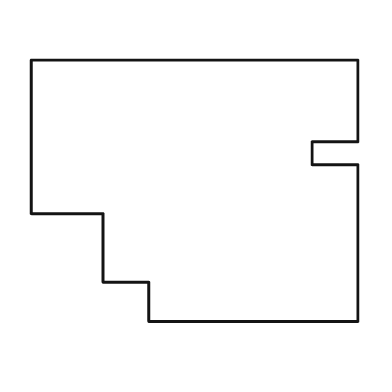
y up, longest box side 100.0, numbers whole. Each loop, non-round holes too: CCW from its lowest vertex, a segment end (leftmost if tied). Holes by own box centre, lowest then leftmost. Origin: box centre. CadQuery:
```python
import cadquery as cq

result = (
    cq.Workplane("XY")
    .moveTo(-14.0, -40.0)
    .lineTo(50.0, -40.0)
    .lineTo(50.0, 8.0)
    .lineTo(36.0, 8.0)
    .lineTo(36.0, 15.0)
    .lineTo(50.0, 15.0)
    .lineTo(50.0, 40.0)
    .lineTo(-50.0, 40.0)
    .lineTo(-50.0, -7.0)
    .lineTo(-28.0, -7.0)
    .lineTo(-28.0, -28.0)
    .lineTo(-14.0, -28.0)
    .close()
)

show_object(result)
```